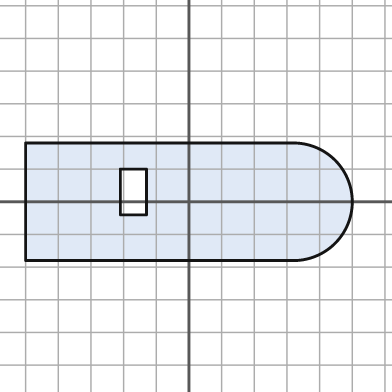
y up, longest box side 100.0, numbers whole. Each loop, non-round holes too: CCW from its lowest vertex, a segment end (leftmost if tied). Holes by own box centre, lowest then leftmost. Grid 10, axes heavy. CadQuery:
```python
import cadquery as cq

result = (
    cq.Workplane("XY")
    .moveTo(-50.0, -18.0)
    .lineTo(32.0, -18.0)
    .threePointArc((50.0, 0.0), (32.0, 18.0))
    .lineTo(-50.0, 18.0)
    .close()
    .moveTo(-21.0, -4.0)
    .lineTo(-13.0, -4.0)
    .lineTo(-13.0, 10.0)
    .lineTo(-21.0, 10.0)
    .close()
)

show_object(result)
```